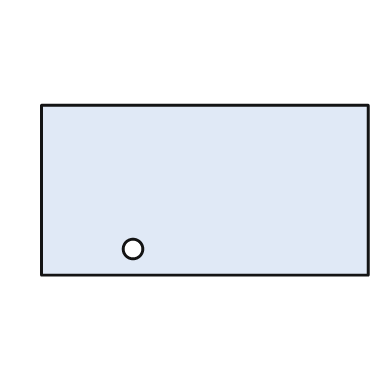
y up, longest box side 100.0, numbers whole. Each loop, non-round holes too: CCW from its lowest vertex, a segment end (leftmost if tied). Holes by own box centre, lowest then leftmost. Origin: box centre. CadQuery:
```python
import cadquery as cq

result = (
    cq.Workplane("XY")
    .moveTo(-50.0, -26.0)
    .lineTo(50.0, -26.0)
    .lineTo(50.0, 26.0)
    .lineTo(-50.0, 26.0)
    .close()
    .moveTo(-22.0, -18.0)
    .circle(3.0)
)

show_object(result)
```